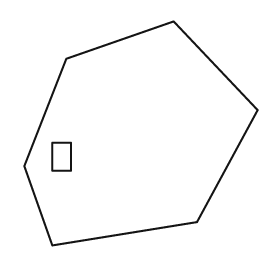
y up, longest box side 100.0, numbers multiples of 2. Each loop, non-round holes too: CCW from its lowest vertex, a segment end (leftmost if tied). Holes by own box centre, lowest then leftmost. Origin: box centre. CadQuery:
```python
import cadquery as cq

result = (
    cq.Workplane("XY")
    .moveTo(-38.0, -48.0)
    .lineTo(24.0, -38.0)
    .lineTo(50.0, 10.0)
    .lineTo(14.0, 48.0)
    .lineTo(-32.0, 32.0)
    .lineTo(-50.0, -14.0)
    .close()
    .moveTo(-38.0, -16.0)
    .lineTo(-30.0, -16.0)
    .lineTo(-30.0, -4.0)
    .lineTo(-38.0, -4.0)
    .close()
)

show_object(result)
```